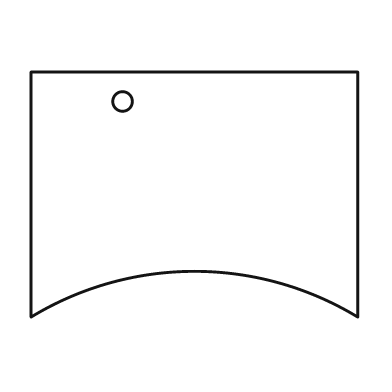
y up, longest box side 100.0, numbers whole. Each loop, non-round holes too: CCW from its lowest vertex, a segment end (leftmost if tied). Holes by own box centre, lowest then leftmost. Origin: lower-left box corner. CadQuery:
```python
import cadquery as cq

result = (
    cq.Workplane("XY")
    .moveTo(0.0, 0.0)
    .threePointArc((50.0, 14.0), (100.0, 0.0))
    .lineTo(100.0, 75.0)
    .lineTo(0.0, 75.0)
    .close()
    .moveTo(28.0, 66.0)
    .circle(3.0)
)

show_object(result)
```